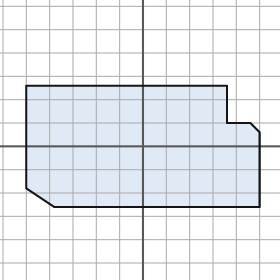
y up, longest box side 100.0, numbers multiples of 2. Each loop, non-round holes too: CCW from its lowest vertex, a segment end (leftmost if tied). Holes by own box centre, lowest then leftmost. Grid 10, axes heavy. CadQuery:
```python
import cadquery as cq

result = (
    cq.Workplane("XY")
    .moveTo(-38.0, -26.0)
    .lineTo(50.0, -26.0)
    .lineTo(50.0, 6.0)
    .lineTo(46.0, 10.0)
    .lineTo(36.0, 10.0)
    .lineTo(36.0, 26.0)
    .lineTo(-50.0, 26.0)
    .lineTo(-50.0, -18.0)
    .close()
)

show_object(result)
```